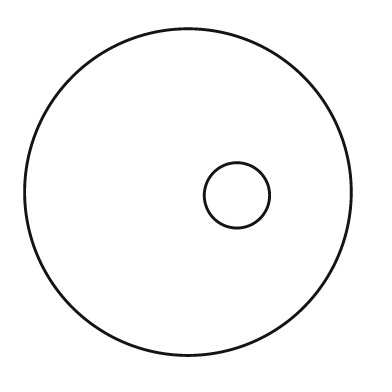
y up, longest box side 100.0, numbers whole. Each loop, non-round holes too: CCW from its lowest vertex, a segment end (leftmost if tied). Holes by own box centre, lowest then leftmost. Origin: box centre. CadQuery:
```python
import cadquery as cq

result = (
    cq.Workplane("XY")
    .moveTo(0.0, 0.0)
    .circle(50.0)
    .moveTo(15.0, -1.0)
    .circle(10.0)
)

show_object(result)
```